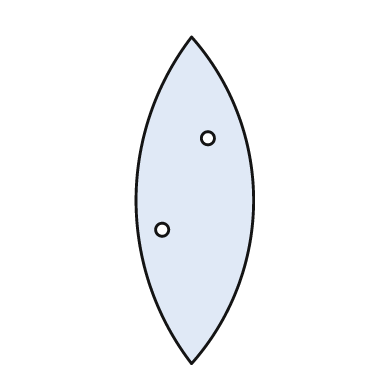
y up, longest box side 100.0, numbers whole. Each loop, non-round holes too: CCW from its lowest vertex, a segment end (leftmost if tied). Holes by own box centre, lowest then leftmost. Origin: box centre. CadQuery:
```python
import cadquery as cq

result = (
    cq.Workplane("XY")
    .moveTo(-1.0, -50.0)
    .threePointArc((18.0, 0.0), (-1.0, 50.0))
    .threePointArc((-18.0, 0.0), (-1.0, -50.0))
    .close()
    .moveTo(-10.0, -9.0)
    .circle(2.0)
    .moveTo(4.0, 19.0)
    .circle(2.0)
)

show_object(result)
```